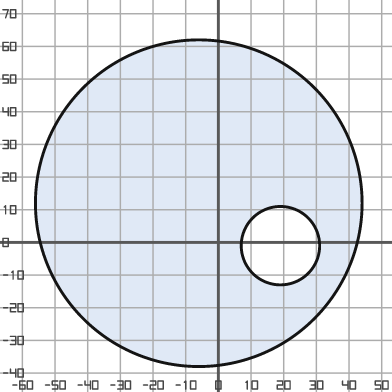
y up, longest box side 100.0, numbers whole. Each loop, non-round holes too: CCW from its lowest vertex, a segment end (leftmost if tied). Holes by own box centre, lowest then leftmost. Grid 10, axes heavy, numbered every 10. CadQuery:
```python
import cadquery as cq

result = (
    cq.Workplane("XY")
    .moveTo(-6.0, 12.0)
    .circle(50.0)
    .moveTo(19.0, -1.0)
    .circle(12.0)
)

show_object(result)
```